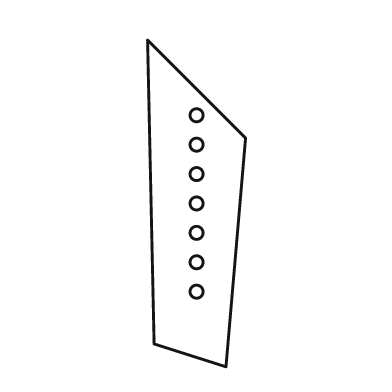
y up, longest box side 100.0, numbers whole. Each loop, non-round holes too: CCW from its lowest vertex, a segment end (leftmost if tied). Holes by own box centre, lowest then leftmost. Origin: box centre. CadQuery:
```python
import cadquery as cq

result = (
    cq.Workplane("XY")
    .moveTo(9.0, -50.0)
    .lineTo(15.0, 20.0)
    .lineTo(-15.0, 50.0)
    .lineTo(-13.0, -43.0)
    .close()
    .moveTo(0.0, -27.0)
    .circle(2.0)
    .moveTo(0.0, -18.0)
    .circle(2.0)
    .moveTo(0.0, -9.0)
    .circle(2.0)
    .moveTo(0.0, 0.0)
    .circle(2.0)
    .moveTo(0.0, 9.0)
    .circle(2.0)
    .moveTo(0.0, 18.0)
    .circle(2.0)
    .moveTo(0.0, 27.0)
    .circle(2.0)
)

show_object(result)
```